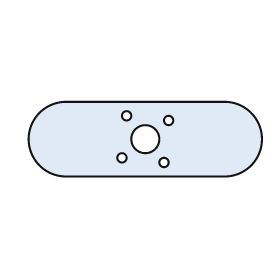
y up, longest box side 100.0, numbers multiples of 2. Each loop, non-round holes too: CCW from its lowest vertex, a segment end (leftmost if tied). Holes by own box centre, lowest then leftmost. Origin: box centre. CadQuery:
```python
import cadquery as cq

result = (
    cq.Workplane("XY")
    .moveTo(-34.0, -16.0)
    .lineTo(34.0, -16.0)
    .threePointArc((50.0, 0.0), (34.0, 16.0))
    .lineTo(-34.0, 16.0)
    .threePointArc((-50.0, 0.0), (-34.0, -16.0))
    .close()
    .moveTo(8.0, -10.0)
    .circle(2.0)
    .moveTo(-10.0, -8.0)
    .circle(2.0)
    .moveTo(0.0, 0.0)
    .circle(6.0)
    .moveTo(10.0, 8.0)
    .circle(2.0)
    .moveTo(-8.0, 10.0)
    .circle(2.0)
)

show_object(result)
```